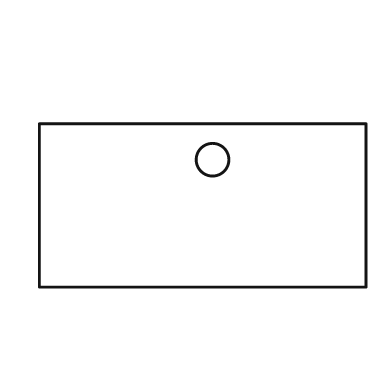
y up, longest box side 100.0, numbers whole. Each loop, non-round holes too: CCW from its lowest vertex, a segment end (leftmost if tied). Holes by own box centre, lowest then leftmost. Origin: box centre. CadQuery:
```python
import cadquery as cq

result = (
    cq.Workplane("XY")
    .moveTo(-50.0, -25.0)
    .lineTo(50.0, -25.0)
    .lineTo(50.0, 25.0)
    .lineTo(-50.0, 25.0)
    .close()
    .moveTo(3.0, 14.0)
    .circle(5.0)
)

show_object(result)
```